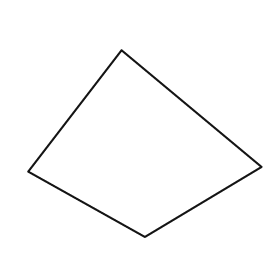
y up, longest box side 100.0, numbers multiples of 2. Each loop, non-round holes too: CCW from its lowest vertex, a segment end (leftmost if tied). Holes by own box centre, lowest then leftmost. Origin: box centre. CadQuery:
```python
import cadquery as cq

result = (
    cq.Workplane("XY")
    .moveTo(0.0, -40.0)
    .lineTo(50.0, -10.0)
    .lineTo(-10.0, 40.0)
    .lineTo(-50.0, -12.0)
    .close()
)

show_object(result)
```